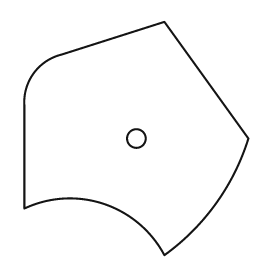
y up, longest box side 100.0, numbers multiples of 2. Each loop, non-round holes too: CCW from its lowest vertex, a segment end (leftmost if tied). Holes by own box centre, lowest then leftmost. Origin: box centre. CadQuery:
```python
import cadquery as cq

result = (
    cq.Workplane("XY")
    .moveTo(12.0, -50.0)
    .threePointArc((34.0, -28.0), (48.0, 0.0))
    .lineTo(12.0, 50.0)
    .lineTo(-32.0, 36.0)
    .threePointArc((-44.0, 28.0), (-48.0, 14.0))
    .lineTo(-48.0, -30.0)
    .threePointArc((-14.0, -28.0), (12.0, -50.0))
    .close()
    .moveTo(0.0, 0.0)
    .circle(4.0)
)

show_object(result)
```